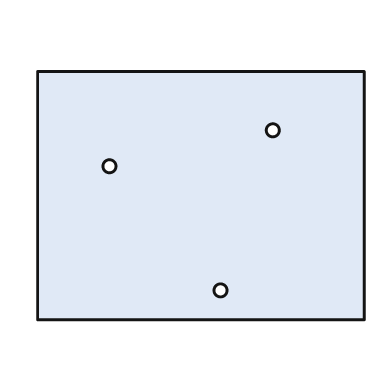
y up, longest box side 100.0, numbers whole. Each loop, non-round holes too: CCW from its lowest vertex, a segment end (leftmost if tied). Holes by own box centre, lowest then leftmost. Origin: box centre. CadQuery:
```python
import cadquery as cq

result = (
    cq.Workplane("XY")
    .moveTo(-50.0, -38.0)
    .lineTo(50.0, -38.0)
    .lineTo(50.0, 38.0)
    .lineTo(-50.0, 38.0)
    .close()
    .moveTo(6.0, -29.0)
    .circle(2.0)
    .moveTo(-28.0, 9.0)
    .circle(2.0)
    .moveTo(22.0, 20.0)
    .circle(2.0)
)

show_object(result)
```